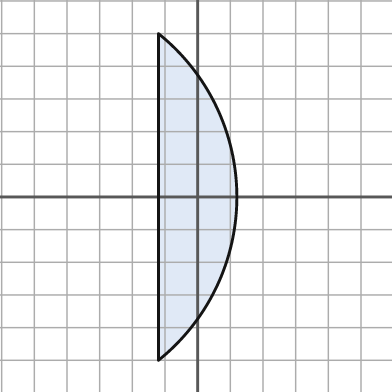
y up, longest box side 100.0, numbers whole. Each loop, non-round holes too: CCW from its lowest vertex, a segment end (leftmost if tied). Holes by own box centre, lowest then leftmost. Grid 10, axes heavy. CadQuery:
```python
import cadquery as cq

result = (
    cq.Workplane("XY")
    .moveTo(-12.0, -50.0)
    .threePointArc((12.0, 0.0), (-12.0, 50.0))
    .close()
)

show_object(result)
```